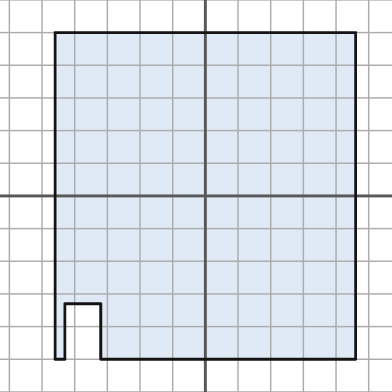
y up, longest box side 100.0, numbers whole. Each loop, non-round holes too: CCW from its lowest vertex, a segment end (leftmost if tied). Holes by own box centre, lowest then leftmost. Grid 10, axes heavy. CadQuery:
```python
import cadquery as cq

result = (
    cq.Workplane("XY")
    .moveTo(-46.0, -50.0)
    .lineTo(-43.0, -50.0)
    .lineTo(-43.0, -33.0)
    .lineTo(-32.0, -33.0)
    .lineTo(-32.0, -50.0)
    .lineTo(46.0, -50.0)
    .lineTo(46.0, 50.0)
    .lineTo(-46.0, 50.0)
    .close()
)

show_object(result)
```